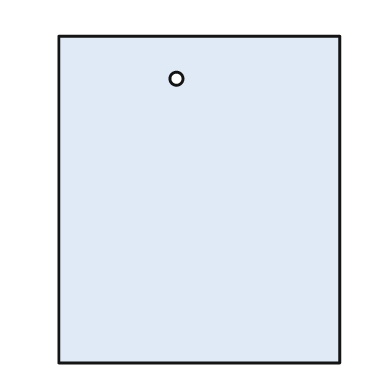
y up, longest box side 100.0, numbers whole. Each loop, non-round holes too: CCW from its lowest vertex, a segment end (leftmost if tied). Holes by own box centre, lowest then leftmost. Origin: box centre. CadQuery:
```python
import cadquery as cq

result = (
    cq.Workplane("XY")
    .moveTo(-43.0, -50.0)
    .lineTo(43.0, -50.0)
    .lineTo(43.0, 50.0)
    .lineTo(-43.0, 50.0)
    .close()
    .moveTo(-7.0, 37.0)
    .circle(2.0)
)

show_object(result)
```